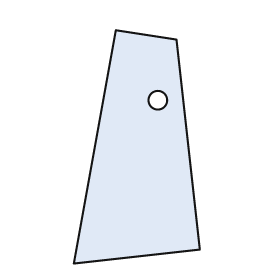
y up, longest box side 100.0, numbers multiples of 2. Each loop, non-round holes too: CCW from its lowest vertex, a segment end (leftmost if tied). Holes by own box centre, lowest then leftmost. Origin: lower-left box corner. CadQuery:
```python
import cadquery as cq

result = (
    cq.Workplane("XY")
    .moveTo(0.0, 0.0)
    .lineTo(54.0, 6.0)
    .lineTo(44.0, 96.0)
    .lineTo(18.0, 100.0)
    .close()
    .moveTo(36.0, 70.0)
    .circle(4.0)
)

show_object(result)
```